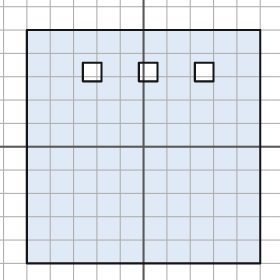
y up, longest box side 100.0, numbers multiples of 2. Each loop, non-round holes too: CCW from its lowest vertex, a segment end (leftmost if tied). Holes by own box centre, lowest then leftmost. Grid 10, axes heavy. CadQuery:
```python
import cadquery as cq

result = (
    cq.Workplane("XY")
    .moveTo(-50.0, -50.0)
    .lineTo(50.0, -50.0)
    .lineTo(50.0, 50.0)
    .lineTo(-50.0, 50.0)
    .close()
    .moveTo(-26.0, 28.0)
    .lineTo(-18.0, 28.0)
    .lineTo(-18.0, 36.0)
    .lineTo(-26.0, 36.0)
    .close()
    .moveTo(-2.0, 28.0)
    .lineTo(6.0, 28.0)
    .lineTo(6.0, 36.0)
    .lineTo(-2.0, 36.0)
    .close()
    .moveTo(22.0, 28.0)
    .lineTo(30.0, 28.0)
    .lineTo(30.0, 36.0)
    .lineTo(22.0, 36.0)
    .close()
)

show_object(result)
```